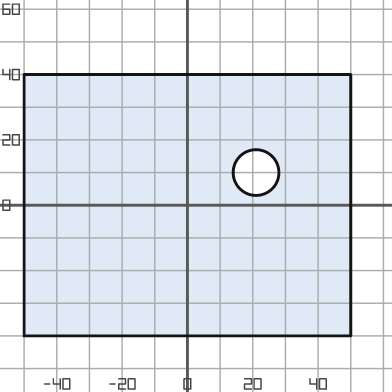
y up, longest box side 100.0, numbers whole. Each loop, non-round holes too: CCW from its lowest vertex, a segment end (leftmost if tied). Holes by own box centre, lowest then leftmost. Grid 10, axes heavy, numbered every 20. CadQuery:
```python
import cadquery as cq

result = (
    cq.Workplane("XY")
    .moveTo(-50.0, -40.0)
    .lineTo(50.0, -40.0)
    .lineTo(50.0, 40.0)
    .lineTo(-50.0, 40.0)
    .close()
    .moveTo(21.0, 10.0)
    .circle(7.0)
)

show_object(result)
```